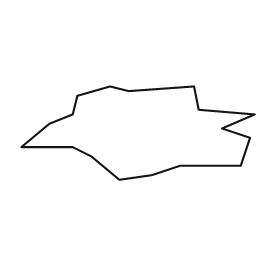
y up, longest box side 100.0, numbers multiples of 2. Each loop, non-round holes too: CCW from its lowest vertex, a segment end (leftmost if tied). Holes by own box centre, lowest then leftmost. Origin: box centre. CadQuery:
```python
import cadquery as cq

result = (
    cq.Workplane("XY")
    .moveTo(-8.0, -20.0)
    .lineTo(6.0, -18.0)
    .lineTo(18.0, -14.0)
    .lineTo(44.0, -14.0)
    .lineTo(48.0, -2.0)
    .lineTo(36.0, 2.0)
    .lineTo(50.0, 8.0)
    .lineTo(26.0, 10.0)
    .lineTo(24.0, 20.0)
    .lineTo(-4.0, 18.0)
    .lineTo(-12.0, 20.0)
    .lineTo(-26.0, 16.0)
    .lineTo(-28.0, 8.0)
    .lineTo(-38.0, 4.0)
    .lineTo(-50.0, -6.0)
    .lineTo(-28.0, -6.0)
    .lineTo(-20.0, -10.0)
    .close()
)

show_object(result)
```